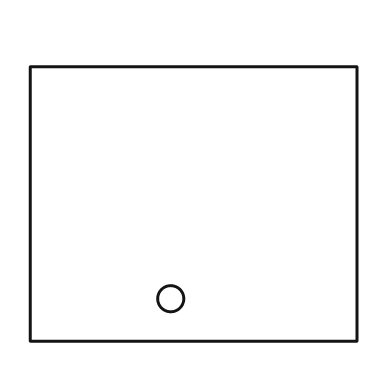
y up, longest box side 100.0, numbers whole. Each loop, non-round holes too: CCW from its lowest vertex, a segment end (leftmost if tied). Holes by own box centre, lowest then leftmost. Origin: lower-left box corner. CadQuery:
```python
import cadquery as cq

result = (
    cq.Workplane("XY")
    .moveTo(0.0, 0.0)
    .lineTo(100.0, 0.0)
    .lineTo(100.0, 84.0)
    .lineTo(0.0, 84.0)
    .close()
    .moveTo(43.0, 13.0)
    .circle(4.0)
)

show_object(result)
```